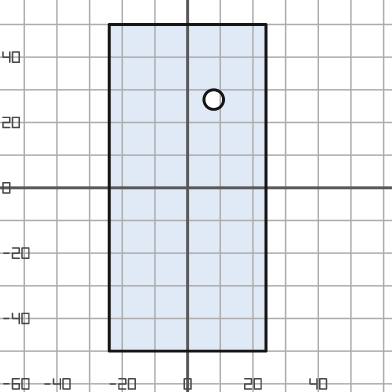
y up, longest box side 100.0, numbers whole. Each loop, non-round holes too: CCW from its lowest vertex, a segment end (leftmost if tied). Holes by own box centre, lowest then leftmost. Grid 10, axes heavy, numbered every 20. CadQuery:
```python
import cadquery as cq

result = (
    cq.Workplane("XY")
    .moveTo(-24.0, -50.0)
    .lineTo(24.0, -50.0)
    .lineTo(24.0, 50.0)
    .lineTo(-24.0, 50.0)
    .close()
    .moveTo(8.0, 27.0)
    .circle(3.0)
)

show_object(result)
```